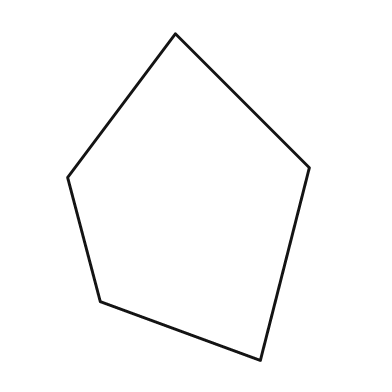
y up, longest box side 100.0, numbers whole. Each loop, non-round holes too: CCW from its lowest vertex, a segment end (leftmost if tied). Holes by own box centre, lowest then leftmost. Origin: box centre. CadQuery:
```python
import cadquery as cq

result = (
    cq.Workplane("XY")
    .moveTo(22.0, -50.0)
    .lineTo(37.0, 9.0)
    .lineTo(-4.0, 50.0)
    .lineTo(-37.0, 6.0)
    .lineTo(-27.0, -32.0)
    .close()
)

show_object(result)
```